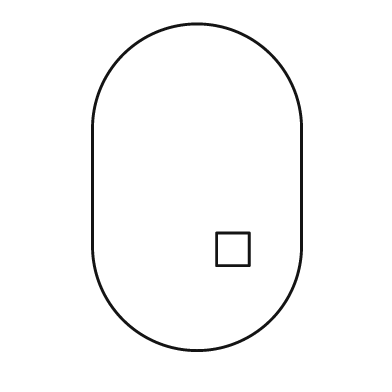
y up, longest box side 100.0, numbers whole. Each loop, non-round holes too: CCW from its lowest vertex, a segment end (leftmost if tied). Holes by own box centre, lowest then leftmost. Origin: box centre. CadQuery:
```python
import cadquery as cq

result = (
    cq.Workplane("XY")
    .moveTo(-32.0, -18.0)
    .threePointArc((0.0, -50.0), (32.0, -18.0))
    .lineTo(32.0, 18.0)
    .threePointArc((0.0, 50.0), (-32.0, 18.0))
    .close()
    .moveTo(6.0, -24.0)
    .lineTo(16.0, -24.0)
    .lineTo(16.0, -14.0)
    .lineTo(6.0, -14.0)
    .close()
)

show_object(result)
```